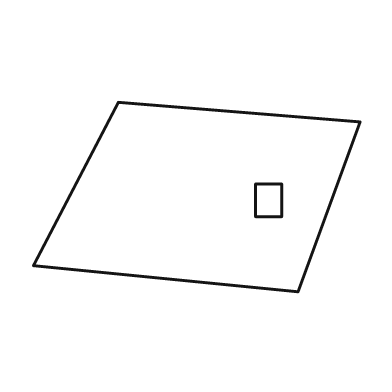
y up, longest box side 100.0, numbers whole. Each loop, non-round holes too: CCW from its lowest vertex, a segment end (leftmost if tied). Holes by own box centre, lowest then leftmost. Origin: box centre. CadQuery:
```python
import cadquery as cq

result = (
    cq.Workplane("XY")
    .moveTo(31.0, -29.0)
    .lineTo(50.0, 23.0)
    .lineTo(-24.0, 29.0)
    .lineTo(-50.0, -21.0)
    .close()
    .moveTo(18.0, -6.0)
    .lineTo(26.0, -6.0)
    .lineTo(26.0, 4.0)
    .lineTo(18.0, 4.0)
    .close()
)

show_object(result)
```